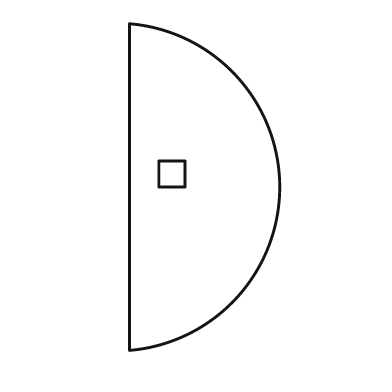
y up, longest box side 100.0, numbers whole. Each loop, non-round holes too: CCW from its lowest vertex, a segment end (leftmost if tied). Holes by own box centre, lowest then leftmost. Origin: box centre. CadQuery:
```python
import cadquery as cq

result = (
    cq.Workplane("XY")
    .moveTo(-23.0, -50.0)
    .threePointArc((23.0, 0.0), (-23.0, 50.0))
    .close()
    .moveTo(-14.0, 0.0)
    .lineTo(-6.0, 0.0)
    .lineTo(-6.0, 8.0)
    .lineTo(-14.0, 8.0)
    .close()
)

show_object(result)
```